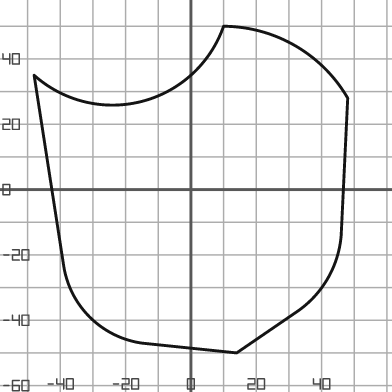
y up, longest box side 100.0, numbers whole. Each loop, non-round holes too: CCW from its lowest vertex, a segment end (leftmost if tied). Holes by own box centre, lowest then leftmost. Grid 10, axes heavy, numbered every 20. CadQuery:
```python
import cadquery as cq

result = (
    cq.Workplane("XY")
    .moveTo(14.0, -50.0)
    .lineTo(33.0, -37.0)
    .threePointArc((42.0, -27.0), (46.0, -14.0))
    .lineTo(48.0, 28.0)
    .threePointArc((32.0, 44.0), (10.0, 50.0))
    .threePointArc((-15.0, 27.0), (-48.0, 35.0))
    .lineTo(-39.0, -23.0)
    .threePointArc((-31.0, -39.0), (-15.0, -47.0))
    .close()
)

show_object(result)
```